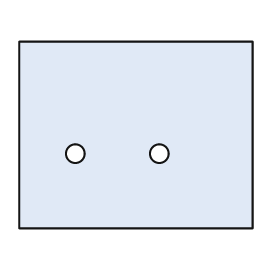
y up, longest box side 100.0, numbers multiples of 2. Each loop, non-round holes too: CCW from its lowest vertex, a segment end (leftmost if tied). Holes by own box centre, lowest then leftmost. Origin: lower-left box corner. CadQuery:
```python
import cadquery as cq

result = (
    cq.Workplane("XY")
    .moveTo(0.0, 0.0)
    .lineTo(100.0, 0.0)
    .lineTo(100.0, 80.0)
    .lineTo(0.0, 80.0)
    .close()
    .moveTo(24.0, 32.0)
    .circle(4.0)
    .moveTo(60.0, 32.0)
    .circle(4.0)
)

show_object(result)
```